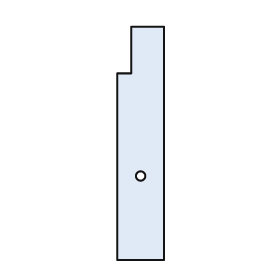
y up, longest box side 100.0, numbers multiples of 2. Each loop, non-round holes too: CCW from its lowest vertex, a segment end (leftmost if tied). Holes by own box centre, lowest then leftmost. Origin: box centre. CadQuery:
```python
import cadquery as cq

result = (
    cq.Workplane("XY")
    .moveTo(-10.0, -50.0)
    .lineTo(10.0, -50.0)
    .lineTo(10.0, 50.0)
    .lineTo(-4.0, 50.0)
    .lineTo(-4.0, 30.0)
    .lineTo(-10.0, 30.0)
    .close()
    .moveTo(0.0, -14.0)
    .circle(2.0)
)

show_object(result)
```